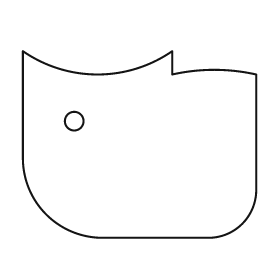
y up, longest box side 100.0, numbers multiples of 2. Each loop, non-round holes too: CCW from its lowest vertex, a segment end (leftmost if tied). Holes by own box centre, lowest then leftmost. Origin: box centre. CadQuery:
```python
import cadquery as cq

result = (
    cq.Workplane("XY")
    .moveTo(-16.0, -40.0)
    .lineTo(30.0, -40.0)
    .threePointArc((44.0, -34.0), (50.0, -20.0))
    .lineTo(50.0, 30.0)
    .threePointArc((32.0, 32.0), (14.0, 30.0))
    .lineTo(14.0, 40.0)
    .threePointArc((-18.0, 30.0), (-50.0, 40.0))
    .lineTo(-50.0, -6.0)
    .threePointArc((-40.0, -30.0), (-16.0, -40.0))
    .close()
    .moveTo(-28.0, 10.0)
    .circle(4.0)
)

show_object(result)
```